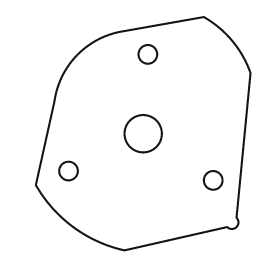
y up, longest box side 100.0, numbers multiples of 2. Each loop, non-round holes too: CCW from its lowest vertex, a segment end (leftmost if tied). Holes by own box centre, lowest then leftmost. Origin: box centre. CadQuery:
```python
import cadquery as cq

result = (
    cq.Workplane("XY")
    .moveTo(-8.0, -50.0)
    .lineTo(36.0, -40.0)
    .threePointArc((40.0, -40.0), (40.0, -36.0))
    .lineTo(46.0, 26.0)
    .threePointArc((38.0, 40.0), (26.0, 50.0))
    .lineTo(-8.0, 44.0)
    .threePointArc((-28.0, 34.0), (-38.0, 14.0))
    .lineTo(-46.0, -22.0)
    .threePointArc((-30.0, -40.0), (-8.0, -50.0))
    .close()
    .moveTo(30.0, -20.0)
    .circle(4.0)
    .moveTo(-32.0, -16.0)
    .circle(4.0)
    .moveTo(0.0, 0.0)
    .circle(8.0)
    .moveTo(2.0, 34.0)
    .circle(4.0)
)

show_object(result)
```